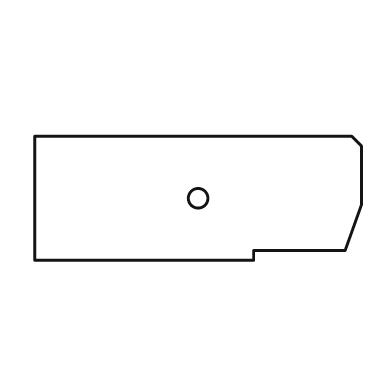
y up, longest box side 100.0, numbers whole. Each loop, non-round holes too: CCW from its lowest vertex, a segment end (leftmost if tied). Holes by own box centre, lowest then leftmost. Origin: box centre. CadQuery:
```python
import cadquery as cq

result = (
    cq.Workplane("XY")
    .moveTo(-50.0, -19.0)
    .lineTo(17.0, -19.0)
    .lineTo(17.0, -16.0)
    .lineTo(45.0, -16.0)
    .lineTo(50.0, -2.0)
    .lineTo(50.0, 16.0)
    .lineTo(47.0, 19.0)
    .lineTo(-50.0, 19.0)
    .close()
    .moveTo(0.0, 0.0)
    .circle(3.0)
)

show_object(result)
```